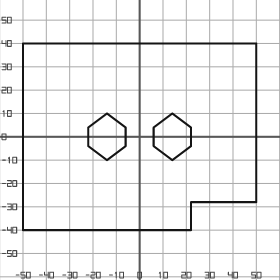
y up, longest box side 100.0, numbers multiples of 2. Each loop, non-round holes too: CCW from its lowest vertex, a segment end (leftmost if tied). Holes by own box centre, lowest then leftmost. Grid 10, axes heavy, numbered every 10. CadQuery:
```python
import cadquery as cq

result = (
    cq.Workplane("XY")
    .moveTo(-50.0, -40.0)
    .lineTo(22.0, -40.0)
    .lineTo(22.0, -28.0)
    .lineTo(50.0, -28.0)
    .lineTo(50.0, 40.0)
    .lineTo(-50.0, 40.0)
    .close()
    .moveTo(-14.0, -10.0)
    .lineTo(-6.0, -4.0)
    .lineTo(-6.0, 4.0)
    .lineTo(-14.0, 10.0)
    .lineTo(-22.0, 4.0)
    .lineTo(-22.0, -4.0)
    .close()
    .moveTo(14.0, -10.0)
    .lineTo(22.0, -4.0)
    .lineTo(22.0, 4.0)
    .lineTo(14.0, 10.0)
    .lineTo(6.0, 4.0)
    .lineTo(6.0, -4.0)
    .close()
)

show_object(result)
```